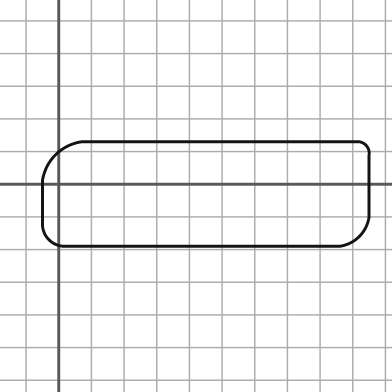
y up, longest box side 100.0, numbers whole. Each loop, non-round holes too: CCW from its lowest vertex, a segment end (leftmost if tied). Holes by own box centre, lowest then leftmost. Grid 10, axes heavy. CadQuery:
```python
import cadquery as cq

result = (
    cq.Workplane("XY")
    .moveTo(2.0, -19.0)
    .lineTo(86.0, -19.0)
    .threePointArc((92.0, -16.0), (95.0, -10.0))
    .lineTo(95.0, 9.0)
    .threePointArc((94.0, 12.0), (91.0, 13.0))
    .lineTo(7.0, 13.0)
    .threePointArc((-1.0, 9.0), (-5.0, 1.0))
    .lineTo(-5.0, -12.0)
    .threePointArc((-3.0, -17.0), (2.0, -19.0))
    .close()
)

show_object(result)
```